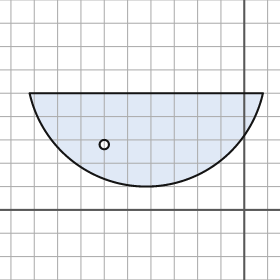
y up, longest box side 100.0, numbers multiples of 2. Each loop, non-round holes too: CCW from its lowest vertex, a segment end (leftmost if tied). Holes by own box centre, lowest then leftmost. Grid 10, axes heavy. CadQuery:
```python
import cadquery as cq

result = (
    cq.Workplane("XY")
    .moveTo(-92.0, 50.0)
    .threePointArc((-42.0, 10.0), (8.0, 50.0))
    .close()
    .moveTo(-60.0, 28.0)
    .circle(2.0)
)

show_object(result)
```